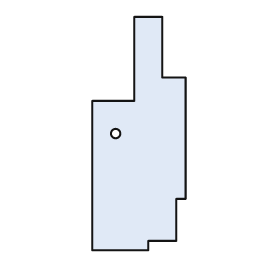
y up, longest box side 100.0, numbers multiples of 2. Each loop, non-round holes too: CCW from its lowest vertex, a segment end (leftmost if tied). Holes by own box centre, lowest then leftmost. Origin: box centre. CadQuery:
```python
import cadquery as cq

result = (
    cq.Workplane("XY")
    .moveTo(-20.0, -50.0)
    .lineTo(4.0, -50.0)
    .lineTo(4.0, -46.0)
    .lineTo(16.0, -46.0)
    .lineTo(16.0, -28.0)
    .lineTo(20.0, -28.0)
    .lineTo(20.0, 24.0)
    .lineTo(10.0, 24.0)
    .lineTo(10.0, 50.0)
    .lineTo(-2.0, 50.0)
    .lineTo(-2.0, 14.0)
    .lineTo(-20.0, 14.0)
    .close()
    .moveTo(-10.0, 0.0)
    .circle(2.0)
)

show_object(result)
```